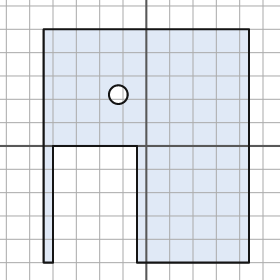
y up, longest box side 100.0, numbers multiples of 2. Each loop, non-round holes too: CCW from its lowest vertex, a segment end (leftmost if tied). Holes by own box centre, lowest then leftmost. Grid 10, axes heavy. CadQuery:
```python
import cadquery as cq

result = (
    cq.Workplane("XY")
    .moveTo(-44.0, -50.0)
    .lineTo(-40.0, -50.0)
    .lineTo(-40.0, 0.0)
    .lineTo(-4.0, 0.0)
    .lineTo(-4.0, -50.0)
    .lineTo(44.0, -50.0)
    .lineTo(44.0, 50.0)
    .lineTo(-44.0, 50.0)
    .close()
    .moveTo(-12.0, 22.0)
    .circle(4.0)
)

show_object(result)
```